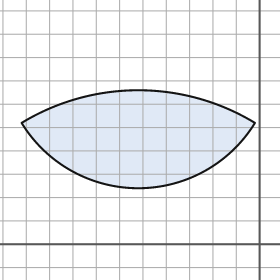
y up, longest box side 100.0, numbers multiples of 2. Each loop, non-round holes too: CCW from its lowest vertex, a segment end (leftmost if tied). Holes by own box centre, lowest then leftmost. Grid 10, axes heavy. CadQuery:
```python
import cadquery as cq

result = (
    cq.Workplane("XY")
    .moveTo(-102.0, 52.0)
    .threePointArc((-52.0, 24.0), (-2.0, 52.0))
    .threePointArc((-52.0, 66.0), (-102.0, 52.0))
    .close()
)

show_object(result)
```